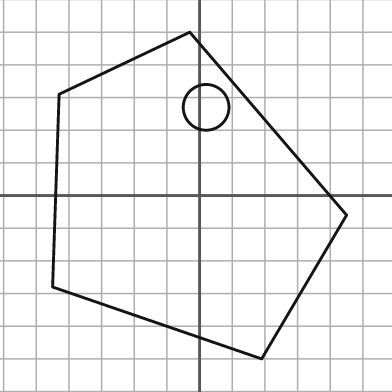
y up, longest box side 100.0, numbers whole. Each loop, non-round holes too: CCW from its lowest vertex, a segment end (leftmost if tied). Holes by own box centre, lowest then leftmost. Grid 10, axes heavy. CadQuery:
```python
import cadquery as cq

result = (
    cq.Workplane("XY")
    .moveTo(19.0, -50.0)
    .lineTo(45.0, -6.0)
    .lineTo(-3.0, 50.0)
    .lineTo(-43.0, 31.0)
    .lineTo(-45.0, -28.0)
    .close()
    .moveTo(2.0, 27.0)
    .circle(7.0)
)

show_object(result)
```